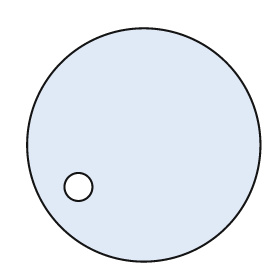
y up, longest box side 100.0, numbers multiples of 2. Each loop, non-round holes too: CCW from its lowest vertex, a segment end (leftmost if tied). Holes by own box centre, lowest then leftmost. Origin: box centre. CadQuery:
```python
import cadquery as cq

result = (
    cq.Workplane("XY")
    .moveTo(0.0, 0.0)
    .circle(50.0)
    .moveTo(-28.0, -18.0)
    .circle(6.0)
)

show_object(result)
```